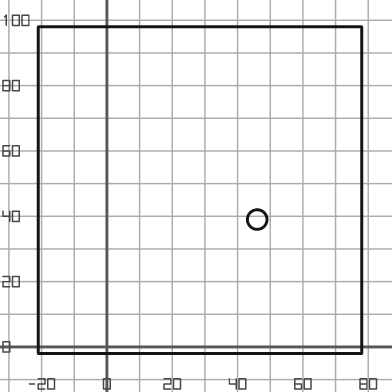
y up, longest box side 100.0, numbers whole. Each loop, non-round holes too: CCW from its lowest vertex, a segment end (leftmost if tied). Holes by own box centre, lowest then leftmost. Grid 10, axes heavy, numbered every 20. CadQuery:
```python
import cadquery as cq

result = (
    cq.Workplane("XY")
    .moveTo(-21.0, -2.0)
    .lineTo(78.0, -2.0)
    .lineTo(78.0, 98.0)
    .lineTo(-21.0, 98.0)
    .close()
    .moveTo(46.0, 39.0)
    .circle(3.0)
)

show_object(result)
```